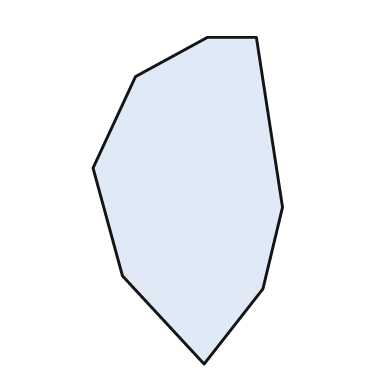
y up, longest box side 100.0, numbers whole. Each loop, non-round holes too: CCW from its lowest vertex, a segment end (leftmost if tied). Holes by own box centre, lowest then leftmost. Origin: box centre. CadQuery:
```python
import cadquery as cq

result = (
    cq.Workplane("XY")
    .moveTo(5.0, -50.0)
    .lineTo(23.0, -27.0)
    .lineTo(29.0, -2.0)
    .lineTo(21.0, 50.0)
    .lineTo(6.0, 50.0)
    .lineTo(-16.0, 38.0)
    .lineTo(-29.0, 10.0)
    .lineTo(-20.0, -23.0)
    .close()
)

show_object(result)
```